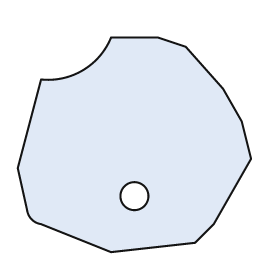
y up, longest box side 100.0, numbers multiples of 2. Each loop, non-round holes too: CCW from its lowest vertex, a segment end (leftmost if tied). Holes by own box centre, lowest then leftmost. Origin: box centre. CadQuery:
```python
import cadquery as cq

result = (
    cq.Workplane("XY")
    .moveTo(-10.0, -46.0)
    .lineTo(26.0, -42.0)
    .lineTo(34.0, -34.0)
    .lineTo(50.0, -6.0)
    .lineTo(46.0, 10.0)
    .lineTo(38.0, 24.0)
    .lineTo(22.0, 42.0)
    .lineTo(10.0, 46.0)
    .lineTo(-10.0, 46.0)
    .threePointArc((-22.0, 32.0), (-40.0, 28.0))
    .lineTo(-50.0, -10.0)
    .lineTo(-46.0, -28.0)
    .threePointArc((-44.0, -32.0), (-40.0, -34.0))
    .close()
    .moveTo(0.0, -22.0)
    .circle(6.0)
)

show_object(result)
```